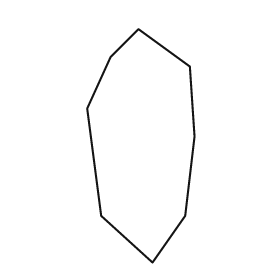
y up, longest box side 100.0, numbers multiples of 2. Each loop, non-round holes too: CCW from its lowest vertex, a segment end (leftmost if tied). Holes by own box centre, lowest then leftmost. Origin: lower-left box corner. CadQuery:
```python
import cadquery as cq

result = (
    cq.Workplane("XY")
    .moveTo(28.0, 0.0)
    .lineTo(42.0, 20.0)
    .lineTo(46.0, 54.0)
    .lineTo(44.0, 84.0)
    .lineTo(22.0, 100.0)
    .lineTo(10.0, 88.0)
    .lineTo(0.0, 66.0)
    .lineTo(6.0, 20.0)
    .close()
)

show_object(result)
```